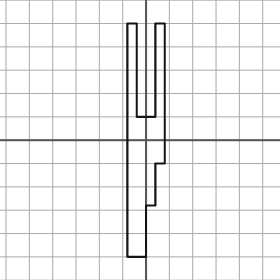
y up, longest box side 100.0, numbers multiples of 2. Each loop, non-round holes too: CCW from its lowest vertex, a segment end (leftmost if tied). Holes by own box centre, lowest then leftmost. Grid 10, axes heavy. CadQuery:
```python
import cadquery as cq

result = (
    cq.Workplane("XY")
    .moveTo(-8.0, -50.0)
    .lineTo(0.0, -50.0)
    .lineTo(0.0, -28.0)
    .lineTo(4.0, -28.0)
    .lineTo(4.0, -10.0)
    .lineTo(8.0, -10.0)
    .lineTo(8.0, 50.0)
    .lineTo(4.0, 50.0)
    .lineTo(4.0, 10.0)
    .lineTo(-4.0, 10.0)
    .lineTo(-4.0, 50.0)
    .lineTo(-8.0, 50.0)
    .close()
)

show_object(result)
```